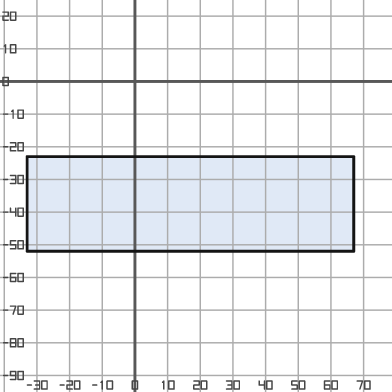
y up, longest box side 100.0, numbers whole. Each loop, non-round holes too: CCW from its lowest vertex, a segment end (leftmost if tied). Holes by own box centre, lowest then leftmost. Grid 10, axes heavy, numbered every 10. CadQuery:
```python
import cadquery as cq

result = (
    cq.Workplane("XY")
    .moveTo(-33.0, -52.0)
    .lineTo(67.0, -52.0)
    .lineTo(67.0, -23.0)
    .lineTo(-33.0, -23.0)
    .close()
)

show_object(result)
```